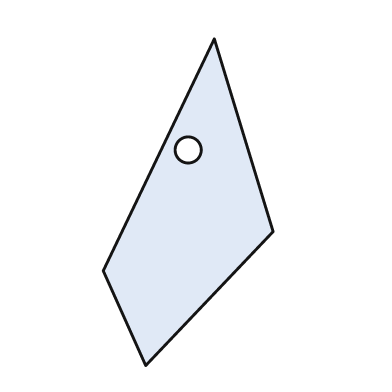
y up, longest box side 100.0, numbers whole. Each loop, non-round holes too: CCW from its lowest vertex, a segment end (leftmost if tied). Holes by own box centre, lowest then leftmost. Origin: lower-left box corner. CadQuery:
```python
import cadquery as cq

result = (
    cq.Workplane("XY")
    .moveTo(13.0, 0.0)
    .lineTo(52.0, 41.0)
    .lineTo(34.0, 100.0)
    .lineTo(0.0, 29.0)
    .close()
    .moveTo(26.0, 66.0)
    .circle(4.0)
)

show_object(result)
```